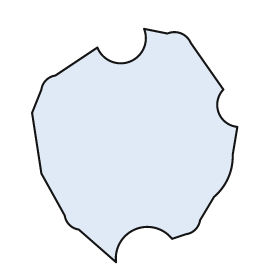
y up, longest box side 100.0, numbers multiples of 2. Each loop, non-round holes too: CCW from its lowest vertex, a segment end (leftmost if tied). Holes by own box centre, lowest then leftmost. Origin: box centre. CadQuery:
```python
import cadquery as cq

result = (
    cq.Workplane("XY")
    .moveTo(-8.0, -50.0)
    .threePointArc((0.0, -36.0), (16.0, -40.0))
    .lineTo(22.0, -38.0)
    .threePointArc((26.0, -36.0), (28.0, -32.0))
    .lineTo(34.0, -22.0)
    .threePointArc((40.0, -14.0), (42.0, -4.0))
    .lineTo(44.0, 8.0)
    .threePointArc((36.0, 14.0), (38.0, 24.0))
    .lineTo(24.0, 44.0)
    .threePointArc((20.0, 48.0), (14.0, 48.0))
    .lineTo(4.0, 50.0)
    .threePointArc((-2.0, 36.0), (-16.0, 42.0))
    .lineTo(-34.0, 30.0)
    .threePointArc((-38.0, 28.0), (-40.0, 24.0))
    .lineTo(-44.0, 14.0)
    .lineTo(-40.0, -12.0)
    .lineTo(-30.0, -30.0)
    .threePointArc((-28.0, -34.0), (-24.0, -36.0))
    .close()
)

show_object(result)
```